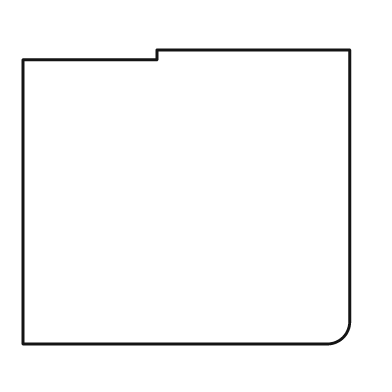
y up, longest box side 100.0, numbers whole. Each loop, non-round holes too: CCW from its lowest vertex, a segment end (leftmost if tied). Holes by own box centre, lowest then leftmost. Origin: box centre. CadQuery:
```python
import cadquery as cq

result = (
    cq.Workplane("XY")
    .moveTo(-50.0, -45.0)
    .lineTo(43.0, -45.0)
    .threePointArc((48.0, -43.0), (50.0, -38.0))
    .lineTo(50.0, 45.0)
    .lineTo(-9.0, 45.0)
    .lineTo(-9.0, 42.0)
    .lineTo(-50.0, 42.0)
    .close()
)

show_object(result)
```